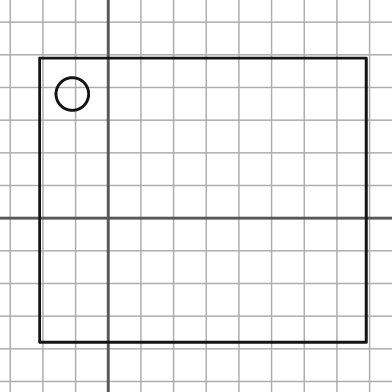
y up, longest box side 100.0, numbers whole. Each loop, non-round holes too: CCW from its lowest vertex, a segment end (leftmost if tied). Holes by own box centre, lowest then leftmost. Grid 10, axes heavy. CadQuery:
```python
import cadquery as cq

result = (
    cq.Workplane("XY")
    .moveTo(-21.0, -38.0)
    .lineTo(79.0, -38.0)
    .lineTo(79.0, 49.0)
    .lineTo(-21.0, 49.0)
    .close()
    .moveTo(-11.0, 38.0)
    .circle(5.0)
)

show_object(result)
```